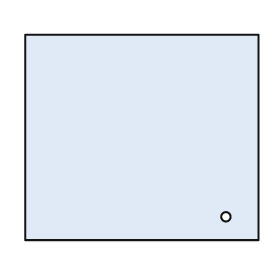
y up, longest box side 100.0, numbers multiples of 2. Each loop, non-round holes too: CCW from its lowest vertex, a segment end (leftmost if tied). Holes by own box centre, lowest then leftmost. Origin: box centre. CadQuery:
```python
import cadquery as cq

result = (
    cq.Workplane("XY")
    .moveTo(-50.0, -44.0)
    .lineTo(50.0, -44.0)
    .lineTo(50.0, 44.0)
    .lineTo(-50.0, 44.0)
    .close()
    .moveTo(36.0, -34.0)
    .circle(2.0)
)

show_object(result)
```